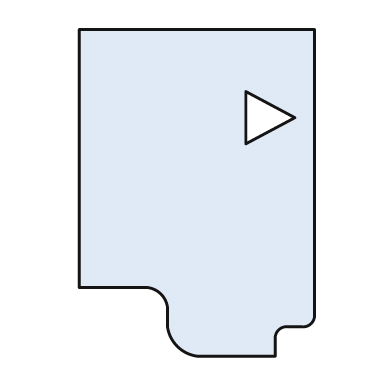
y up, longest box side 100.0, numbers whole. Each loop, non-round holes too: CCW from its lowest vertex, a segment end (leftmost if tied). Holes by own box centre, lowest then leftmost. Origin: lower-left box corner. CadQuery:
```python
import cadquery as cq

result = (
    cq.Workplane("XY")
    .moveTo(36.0, 0.0)
    .lineTo(60.0, 0.0)
    .lineTo(60.0, 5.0)
    .threePointArc((61.0, 8.0), (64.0, 9.0))
    .lineTo(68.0, 9.0)
    .threePointArc((71.0, 10.0), (72.0, 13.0))
    .lineTo(72.0, 100.0)
    .lineTo(0.0, 100.0)
    .lineTo(0.0, 21.0)
    .lineTo(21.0, 21.0)
    .threePointArc((25.0, 19.0), (27.0, 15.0))
    .lineTo(27.0, 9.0)
    .threePointArc((30.0, 3.0), (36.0, 0.0))
    .close()
    .moveTo(51.0, 65.0)
    .lineTo(66.0, 73.0)
    .lineTo(51.0, 81.0)
    .close()
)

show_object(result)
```